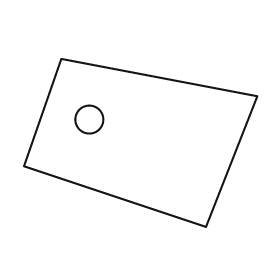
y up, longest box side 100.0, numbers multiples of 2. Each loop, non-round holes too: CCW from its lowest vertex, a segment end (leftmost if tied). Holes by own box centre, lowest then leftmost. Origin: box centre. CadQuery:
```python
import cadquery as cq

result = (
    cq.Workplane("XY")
    .moveTo(28.0, -36.0)
    .lineTo(50.0, 20.0)
    .lineTo(-34.0, 36.0)
    .lineTo(-50.0, -10.0)
    .close()
    .moveTo(-22.0, 10.0)
    .circle(6.0)
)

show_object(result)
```